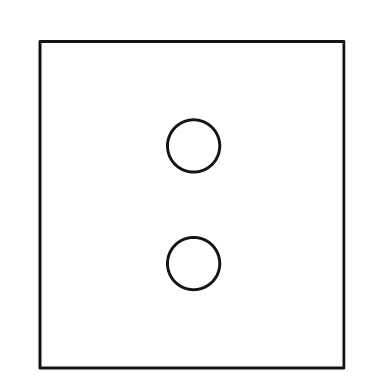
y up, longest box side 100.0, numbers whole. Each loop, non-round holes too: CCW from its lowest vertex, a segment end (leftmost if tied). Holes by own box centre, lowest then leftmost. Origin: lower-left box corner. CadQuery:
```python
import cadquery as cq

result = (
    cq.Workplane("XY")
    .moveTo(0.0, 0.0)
    .lineTo(93.0, 0.0)
    .lineTo(93.0, 100.0)
    .lineTo(0.0, 100.0)
    .close()
    .moveTo(47.0, 32.0)
    .circle(8.0)
    .moveTo(47.0, 68.0)
    .circle(8.0)
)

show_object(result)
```